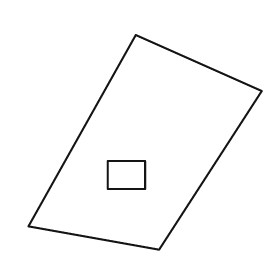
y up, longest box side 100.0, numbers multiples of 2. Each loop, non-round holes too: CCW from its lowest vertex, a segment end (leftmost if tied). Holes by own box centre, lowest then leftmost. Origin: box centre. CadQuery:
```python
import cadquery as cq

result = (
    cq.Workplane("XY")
    .moveTo(6.0, -46.0)
    .lineTo(50.0, 22.0)
    .lineTo(-4.0, 46.0)
    .lineTo(-50.0, -36.0)
    .close()
    .moveTo(-16.0, -20.0)
    .lineTo(0.0, -20.0)
    .lineTo(0.0, -8.0)
    .lineTo(-16.0, -8.0)
    .close()
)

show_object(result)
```